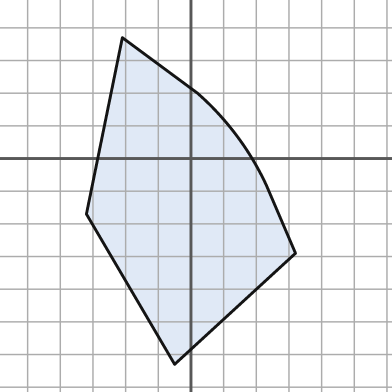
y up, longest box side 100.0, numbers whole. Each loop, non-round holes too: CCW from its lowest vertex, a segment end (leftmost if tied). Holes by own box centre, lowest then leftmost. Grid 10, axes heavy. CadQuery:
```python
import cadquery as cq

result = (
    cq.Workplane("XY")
    .moveTo(-5.0, -63.0)
    .lineTo(32.0, -29.0)
    .lineTo(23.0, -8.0)
    .threePointArc((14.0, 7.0), (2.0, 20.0))
    .lineTo(-21.0, 37.0)
    .lineTo(-32.0, -17.0)
    .close()
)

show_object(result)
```